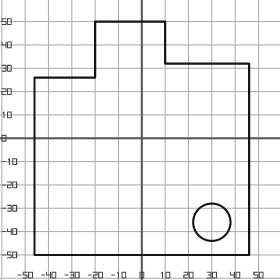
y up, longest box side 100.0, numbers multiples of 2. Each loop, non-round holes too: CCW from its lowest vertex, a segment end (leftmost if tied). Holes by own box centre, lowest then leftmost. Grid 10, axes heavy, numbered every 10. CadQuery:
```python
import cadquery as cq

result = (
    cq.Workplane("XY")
    .moveTo(-46.0, -50.0)
    .lineTo(46.0, -50.0)
    .lineTo(46.0, 32.0)
    .lineTo(10.0, 32.0)
    .lineTo(10.0, 50.0)
    .lineTo(-20.0, 50.0)
    .lineTo(-20.0, 26.0)
    .lineTo(-46.0, 26.0)
    .close()
    .moveTo(30.0, -36.0)
    .circle(8.0)
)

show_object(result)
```